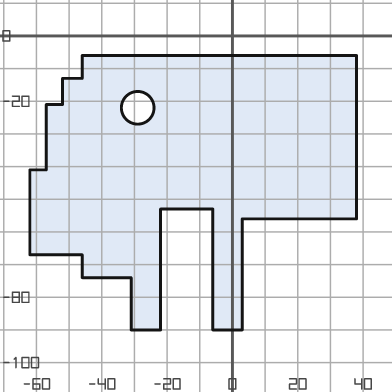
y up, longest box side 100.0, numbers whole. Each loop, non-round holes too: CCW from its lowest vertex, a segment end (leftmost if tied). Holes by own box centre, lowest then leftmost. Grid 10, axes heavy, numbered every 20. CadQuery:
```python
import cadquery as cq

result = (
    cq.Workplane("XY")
    .moveTo(-31.0, -90.0)
    .lineTo(-22.0, -90.0)
    .lineTo(-22.0, -53.0)
    .lineTo(-6.0, -53.0)
    .lineTo(-6.0, -90.0)
    .lineTo(3.0, -90.0)
    .lineTo(3.0, -56.0)
    .lineTo(38.0, -56.0)
    .lineTo(38.0, -6.0)
    .lineTo(-46.0, -6.0)
    .lineTo(-46.0, -13.0)
    .lineTo(-52.0, -13.0)
    .lineTo(-52.0, -21.0)
    .lineTo(-57.0, -21.0)
    .lineTo(-57.0, -41.0)
    .lineTo(-62.0, -41.0)
    .lineTo(-62.0, -67.0)
    .lineTo(-46.0, -67.0)
    .lineTo(-46.0, -74.0)
    .lineTo(-31.0, -74.0)
    .close()
    .moveTo(-29.0, -22.0)
    .circle(5.0)
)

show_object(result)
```